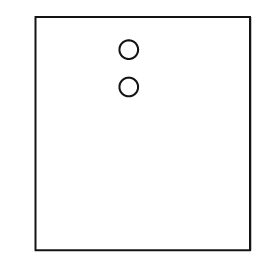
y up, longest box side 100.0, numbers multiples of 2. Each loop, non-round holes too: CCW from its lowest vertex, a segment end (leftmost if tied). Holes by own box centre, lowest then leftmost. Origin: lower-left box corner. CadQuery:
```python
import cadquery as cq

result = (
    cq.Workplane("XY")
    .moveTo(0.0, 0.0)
    .lineTo(92.0, 0.0)
    .lineTo(92.0, 100.0)
    .lineTo(0.0, 100.0)
    .close()
    .moveTo(40.0, 70.0)
    .circle(4.0)
    .moveTo(40.0, 86.0)
    .circle(4.0)
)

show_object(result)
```